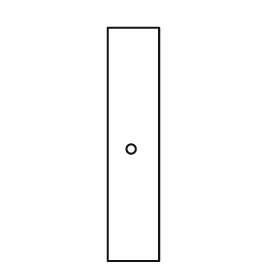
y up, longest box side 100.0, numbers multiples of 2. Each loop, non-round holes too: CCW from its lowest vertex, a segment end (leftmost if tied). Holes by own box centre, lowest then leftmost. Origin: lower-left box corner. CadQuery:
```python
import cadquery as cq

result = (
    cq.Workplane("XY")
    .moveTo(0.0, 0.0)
    .lineTo(22.0, 0.0)
    .lineTo(22.0, 100.0)
    .lineTo(0.0, 100.0)
    .close()
    .moveTo(10.0, 48.0)
    .circle(2.0)
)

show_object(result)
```